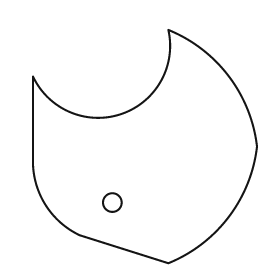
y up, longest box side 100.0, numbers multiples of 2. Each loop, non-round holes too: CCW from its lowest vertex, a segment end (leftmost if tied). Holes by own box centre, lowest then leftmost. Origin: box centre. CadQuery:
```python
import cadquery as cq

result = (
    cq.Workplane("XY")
    .moveTo(10.0, -50.0)
    .threePointArc((36.0, -30.0), (48.0, 0.0))
    .threePointArc((36.0, 30.0), (10.0, 50.0))
    .threePointArc((-10.0, 14.0), (-48.0, 30.0))
    .lineTo(-48.0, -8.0)
    .threePointArc((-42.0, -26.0), (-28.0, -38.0))
    .close()
    .moveTo(-14.0, -24.0)
    .circle(4.0)
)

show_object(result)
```